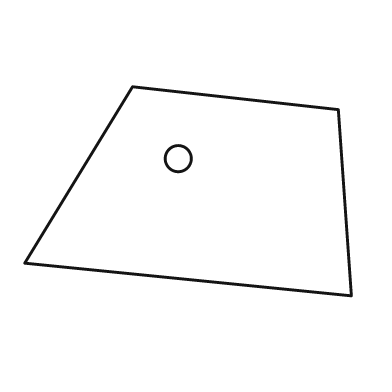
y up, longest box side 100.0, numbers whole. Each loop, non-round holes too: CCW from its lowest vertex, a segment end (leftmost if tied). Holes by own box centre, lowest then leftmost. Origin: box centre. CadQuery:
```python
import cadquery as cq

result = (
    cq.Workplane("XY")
    .moveTo(50.0, -32.0)
    .lineTo(46.0, 25.0)
    .lineTo(-17.0, 32.0)
    .lineTo(-50.0, -22.0)
    .close()
    .moveTo(-3.0, 10.0)
    .circle(4.0)
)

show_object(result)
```